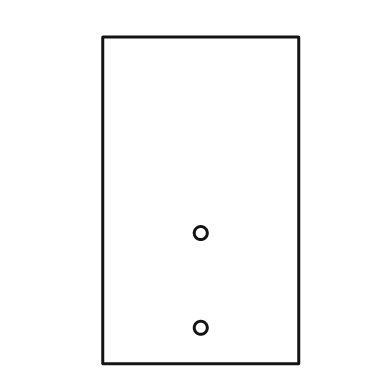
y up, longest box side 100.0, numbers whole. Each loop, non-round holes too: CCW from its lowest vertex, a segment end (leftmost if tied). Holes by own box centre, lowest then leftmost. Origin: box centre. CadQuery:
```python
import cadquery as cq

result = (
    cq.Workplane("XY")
    .moveTo(-30.0, -50.0)
    .lineTo(30.0, -50.0)
    .lineTo(30.0, 50.0)
    .lineTo(-30.0, 50.0)
    .close()
    .moveTo(0.0, -39.0)
    .circle(2.0)
    .moveTo(0.0, -10.0)
    .circle(2.0)
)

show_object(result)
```